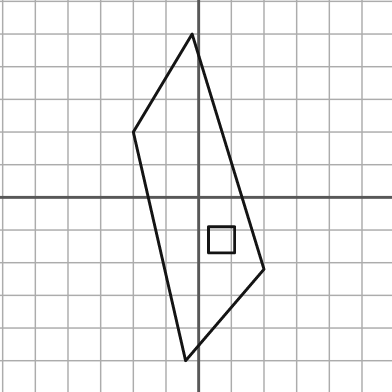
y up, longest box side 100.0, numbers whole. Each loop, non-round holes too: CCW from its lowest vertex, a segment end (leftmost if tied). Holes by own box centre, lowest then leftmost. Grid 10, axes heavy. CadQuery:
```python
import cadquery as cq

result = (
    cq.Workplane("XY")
    .moveTo(-4.0, -50.0)
    .lineTo(20.0, -22.0)
    .lineTo(-2.0, 50.0)
    .lineTo(-20.0, 20.0)
    .close()
    .moveTo(3.0, -17.0)
    .lineTo(11.0, -17.0)
    .lineTo(11.0, -9.0)
    .lineTo(3.0, -9.0)
    .close()
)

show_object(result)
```